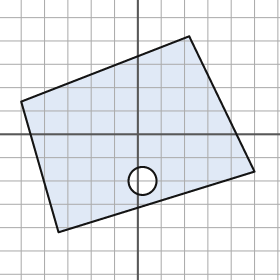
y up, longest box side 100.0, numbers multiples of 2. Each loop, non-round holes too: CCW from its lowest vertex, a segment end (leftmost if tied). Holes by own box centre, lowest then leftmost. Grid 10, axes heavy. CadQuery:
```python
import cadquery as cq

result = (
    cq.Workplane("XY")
    .moveTo(-34.0, -42.0)
    .lineTo(50.0, -16.0)
    .lineTo(22.0, 42.0)
    .lineTo(-50.0, 14.0)
    .close()
    .moveTo(2.0, -20.0)
    .circle(6.0)
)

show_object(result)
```